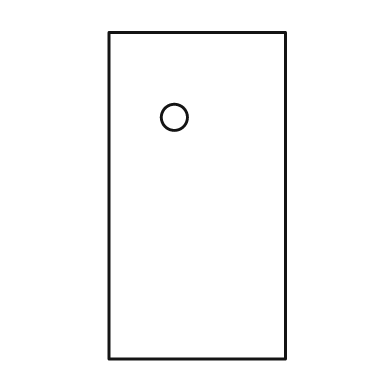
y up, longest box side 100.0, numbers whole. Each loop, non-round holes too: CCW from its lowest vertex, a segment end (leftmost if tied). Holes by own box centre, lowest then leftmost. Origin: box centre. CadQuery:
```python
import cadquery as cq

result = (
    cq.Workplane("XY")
    .moveTo(-27.0, -50.0)
    .lineTo(27.0, -50.0)
    .lineTo(27.0, 50.0)
    .lineTo(-27.0, 50.0)
    .close()
    .moveTo(-7.0, 24.0)
    .circle(4.0)
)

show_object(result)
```